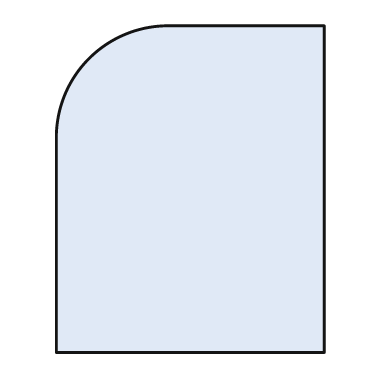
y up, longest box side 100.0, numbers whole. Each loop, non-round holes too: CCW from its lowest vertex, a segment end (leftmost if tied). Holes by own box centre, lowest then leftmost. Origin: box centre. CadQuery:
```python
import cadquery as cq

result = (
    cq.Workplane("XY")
    .moveTo(-41.0, -50.0)
    .lineTo(41.0, -50.0)
    .lineTo(41.0, 50.0)
    .lineTo(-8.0, 50.0)
    .threePointArc((-31.0, 40.0), (-41.0, 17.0))
    .close()
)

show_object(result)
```